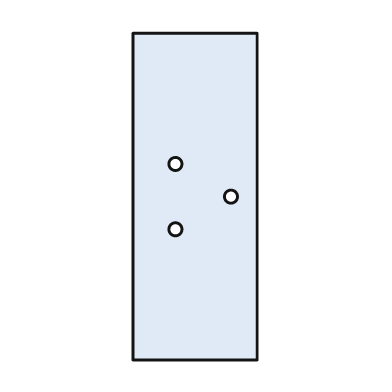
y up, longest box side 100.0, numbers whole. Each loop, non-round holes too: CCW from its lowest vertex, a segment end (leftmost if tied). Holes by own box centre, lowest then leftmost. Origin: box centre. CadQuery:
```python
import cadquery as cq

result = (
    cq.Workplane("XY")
    .moveTo(-19.0, -50.0)
    .lineTo(19.0, -50.0)
    .lineTo(19.0, 50.0)
    .lineTo(-19.0, 50.0)
    .close()
    .moveTo(-6.0, -10.0)
    .circle(2.0)
    .moveTo(11.0, 0.0)
    .circle(2.0)
    .moveTo(-6.0, 10.0)
    .circle(2.0)
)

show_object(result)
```